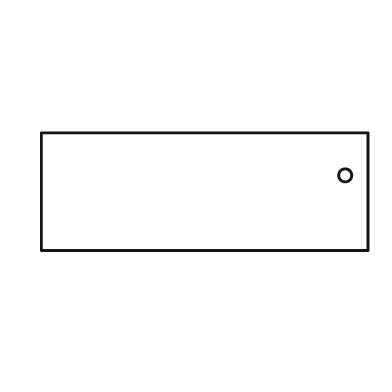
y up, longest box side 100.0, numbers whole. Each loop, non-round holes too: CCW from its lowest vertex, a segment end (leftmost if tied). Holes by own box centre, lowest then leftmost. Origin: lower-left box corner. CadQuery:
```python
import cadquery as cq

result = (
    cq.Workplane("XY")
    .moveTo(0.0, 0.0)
    .lineTo(100.0, 0.0)
    .lineTo(100.0, 36.0)
    .lineTo(0.0, 36.0)
    .close()
    .moveTo(93.0, 23.0)
    .circle(2.0)
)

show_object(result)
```